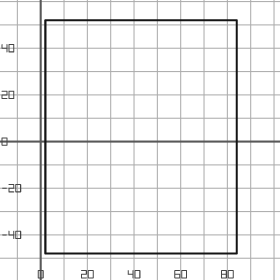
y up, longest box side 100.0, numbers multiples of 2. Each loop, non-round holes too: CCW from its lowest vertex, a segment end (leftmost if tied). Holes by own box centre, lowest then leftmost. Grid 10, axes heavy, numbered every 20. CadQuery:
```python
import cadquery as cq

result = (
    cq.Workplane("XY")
    .moveTo(2.0, -48.0)
    .lineTo(84.0, -48.0)
    .lineTo(84.0, 52.0)
    .lineTo(2.0, 52.0)
    .close()
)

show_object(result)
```